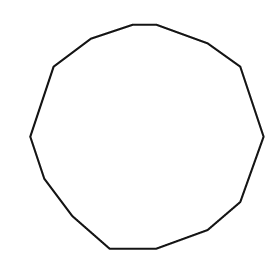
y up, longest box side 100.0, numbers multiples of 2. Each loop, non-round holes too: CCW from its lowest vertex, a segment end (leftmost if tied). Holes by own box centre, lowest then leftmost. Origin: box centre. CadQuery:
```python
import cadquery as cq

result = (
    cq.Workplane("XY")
    .moveTo(-16.0, -48.0)
    .lineTo(4.0, -48.0)
    .lineTo(26.0, -40.0)
    .lineTo(40.0, -28.0)
    .lineTo(50.0, 0.0)
    .lineTo(40.0, 30.0)
    .lineTo(26.0, 40.0)
    .lineTo(4.0, 48.0)
    .lineTo(-6.0, 48.0)
    .lineTo(-24.0, 42.0)
    .lineTo(-40.0, 30.0)
    .lineTo(-50.0, 0.0)
    .lineTo(-44.0, -18.0)
    .lineTo(-32.0, -34.0)
    .close()
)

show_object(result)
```